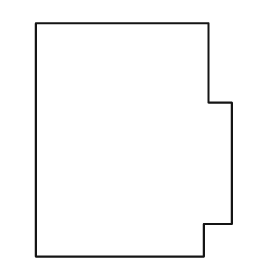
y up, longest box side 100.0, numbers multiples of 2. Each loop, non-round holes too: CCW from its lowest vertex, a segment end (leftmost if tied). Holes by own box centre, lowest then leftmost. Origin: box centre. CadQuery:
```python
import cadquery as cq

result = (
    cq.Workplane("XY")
    .moveTo(-42.0, -50.0)
    .lineTo(30.0, -50.0)
    .lineTo(30.0, -36.0)
    .lineTo(42.0, -36.0)
    .lineTo(42.0, 16.0)
    .lineTo(32.0, 16.0)
    .lineTo(32.0, 50.0)
    .lineTo(-42.0, 50.0)
    .close()
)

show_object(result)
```